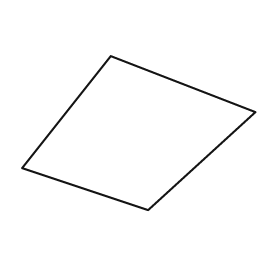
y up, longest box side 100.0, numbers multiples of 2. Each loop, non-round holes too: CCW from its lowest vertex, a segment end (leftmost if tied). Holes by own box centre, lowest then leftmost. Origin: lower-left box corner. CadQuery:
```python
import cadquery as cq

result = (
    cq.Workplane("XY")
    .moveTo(54.0, 0.0)
    .lineTo(100.0, 42.0)
    .lineTo(38.0, 66.0)
    .lineTo(0.0, 18.0)
    .close()
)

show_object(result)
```